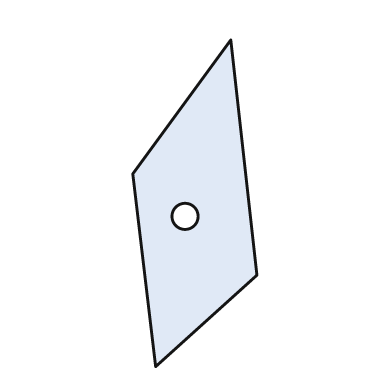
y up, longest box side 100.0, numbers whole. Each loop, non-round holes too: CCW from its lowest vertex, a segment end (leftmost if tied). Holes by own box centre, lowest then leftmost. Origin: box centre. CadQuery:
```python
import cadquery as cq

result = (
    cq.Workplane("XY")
    .moveTo(-12.0, -50.0)
    .lineTo(19.0, -22.0)
    .lineTo(11.0, 50.0)
    .lineTo(-19.0, 9.0)
    .close()
    .moveTo(-3.0, -4.0)
    .circle(4.0)
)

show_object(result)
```